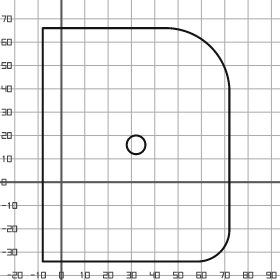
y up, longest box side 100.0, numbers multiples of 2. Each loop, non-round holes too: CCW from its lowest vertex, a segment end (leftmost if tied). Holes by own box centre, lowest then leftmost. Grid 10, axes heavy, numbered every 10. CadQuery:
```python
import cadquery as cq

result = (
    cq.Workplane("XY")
    .moveTo(-8.0, -34.0)
    .lineTo(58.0, -34.0)
    .threePointArc((68.0, -30.0), (72.0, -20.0))
    .lineTo(72.0, 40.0)
    .threePointArc((64.0, 58.0), (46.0, 66.0))
    .lineTo(-8.0, 66.0)
    .close()
    .moveTo(32.0, 16.0)
    .circle(4.0)
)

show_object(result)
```